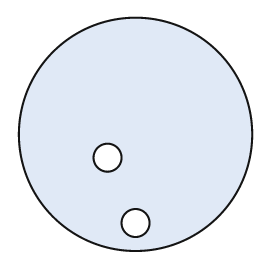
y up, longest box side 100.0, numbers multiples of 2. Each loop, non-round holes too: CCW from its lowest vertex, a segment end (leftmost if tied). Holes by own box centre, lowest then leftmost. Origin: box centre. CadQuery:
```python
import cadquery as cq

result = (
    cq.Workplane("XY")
    .moveTo(0.0, 0.0)
    .circle(50.0)
    .moveTo(0.0, -38.0)
    .circle(6.0)
    .moveTo(-12.0, -10.0)
    .circle(6.0)
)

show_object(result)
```